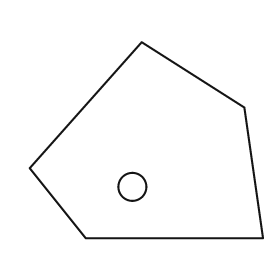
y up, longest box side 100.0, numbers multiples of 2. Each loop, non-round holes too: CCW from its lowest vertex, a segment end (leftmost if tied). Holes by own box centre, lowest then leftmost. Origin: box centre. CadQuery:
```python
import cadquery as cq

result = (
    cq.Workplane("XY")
    .moveTo(-26.0, -42.0)
    .lineTo(50.0, -42.0)
    .lineTo(42.0, 14.0)
    .lineTo(-2.0, 42.0)
    .lineTo(-50.0, -12.0)
    .close()
    .moveTo(-6.0, -20.0)
    .circle(6.0)
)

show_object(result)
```